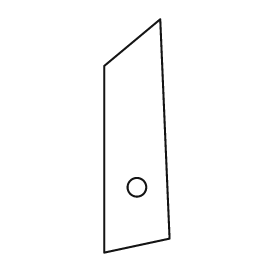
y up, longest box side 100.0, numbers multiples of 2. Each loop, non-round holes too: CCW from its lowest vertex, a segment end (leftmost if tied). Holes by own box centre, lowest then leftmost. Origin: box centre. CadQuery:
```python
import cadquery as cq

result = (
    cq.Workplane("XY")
    .moveTo(-14.0, -50.0)
    .lineTo(14.0, -44.0)
    .lineTo(10.0, 50.0)
    .lineTo(-14.0, 30.0)
    .close()
    .moveTo(0.0, -22.0)
    .circle(4.0)
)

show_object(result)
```